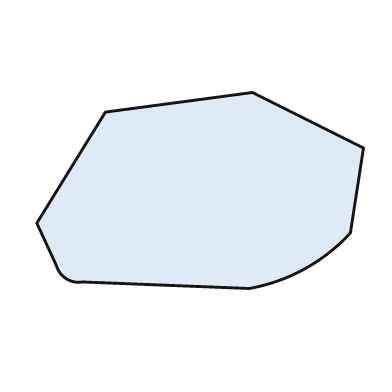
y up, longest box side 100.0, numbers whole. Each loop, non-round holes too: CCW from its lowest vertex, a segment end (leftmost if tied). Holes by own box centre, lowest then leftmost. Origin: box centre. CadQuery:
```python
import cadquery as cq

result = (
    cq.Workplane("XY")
    .moveTo(15.0, -30.0)
    .threePointArc((32.0, -24.0), (46.0, -13.0))
    .lineTo(50.0, 13.0)
    .lineTo(16.0, 30.0)
    .lineTo(-29.0, 24.0)
    .lineTo(-50.0, -10.0)
    .lineTo(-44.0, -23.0)
    .threePointArc((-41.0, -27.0), (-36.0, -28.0))
    .close()
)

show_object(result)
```